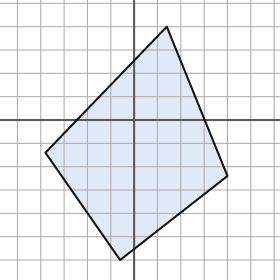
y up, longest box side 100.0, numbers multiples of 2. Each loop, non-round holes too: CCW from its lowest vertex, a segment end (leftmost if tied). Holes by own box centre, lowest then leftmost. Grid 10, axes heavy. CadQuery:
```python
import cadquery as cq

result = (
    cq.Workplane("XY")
    .moveTo(-6.0, -60.0)
    .lineTo(40.0, -24.0)
    .lineTo(14.0, 40.0)
    .lineTo(-38.0, -14.0)
    .close()
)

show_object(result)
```